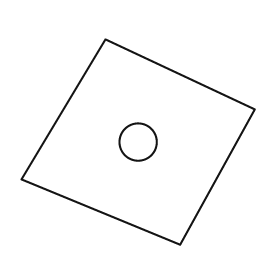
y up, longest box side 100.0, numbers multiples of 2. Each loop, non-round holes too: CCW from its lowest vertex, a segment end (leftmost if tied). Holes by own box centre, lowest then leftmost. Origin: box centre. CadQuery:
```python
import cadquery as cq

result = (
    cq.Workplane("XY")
    .moveTo(18.0, -44.0)
    .lineTo(50.0, 14.0)
    .lineTo(-14.0, 44.0)
    .lineTo(-50.0, -16.0)
    .close()
    .moveTo(0.0, 0.0)
    .circle(8.0)
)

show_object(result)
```